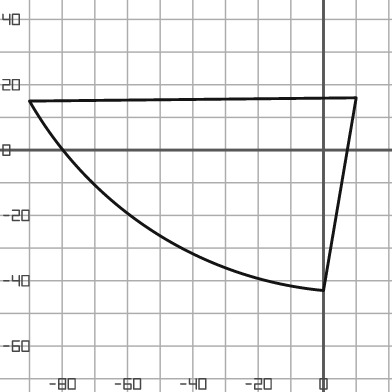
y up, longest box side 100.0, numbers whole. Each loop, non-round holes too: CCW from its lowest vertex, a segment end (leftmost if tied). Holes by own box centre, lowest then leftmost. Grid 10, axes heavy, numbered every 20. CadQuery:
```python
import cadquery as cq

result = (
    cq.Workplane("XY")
    .moveTo(0.0, -43.0)
    .lineTo(10.0, 16.0)
    .lineTo(-90.0, 15.0)
    .threePointArc((-52.0, -25.0), (0.0, -43.0))
    .close()
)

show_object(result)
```